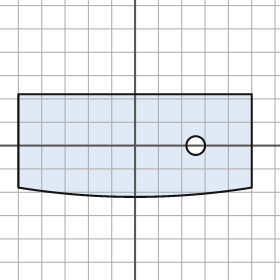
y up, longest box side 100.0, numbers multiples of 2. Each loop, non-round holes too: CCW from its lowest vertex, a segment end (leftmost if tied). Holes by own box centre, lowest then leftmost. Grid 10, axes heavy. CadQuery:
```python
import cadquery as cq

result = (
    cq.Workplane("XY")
    .moveTo(-50.0, -18.0)
    .threePointArc((0.0, -22.0), (50.0, -18.0))
    .lineTo(50.0, 22.0)
    .lineTo(-50.0, 22.0)
    .close()
    .moveTo(26.0, 0.0)
    .circle(4.0)
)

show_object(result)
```